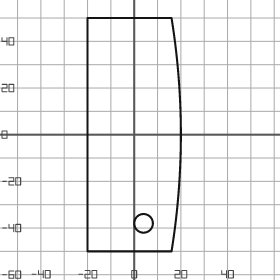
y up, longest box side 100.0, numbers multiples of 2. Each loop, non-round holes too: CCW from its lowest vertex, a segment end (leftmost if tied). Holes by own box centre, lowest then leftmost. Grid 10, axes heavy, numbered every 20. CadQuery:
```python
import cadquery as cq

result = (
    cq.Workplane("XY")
    .moveTo(-20.0, -50.0)
    .lineTo(16.0, -50.0)
    .threePointArc((20.0, 0.0), (16.0, 50.0))
    .lineTo(-20.0, 50.0)
    .close()
    .moveTo(4.0, -38.0)
    .circle(4.0)
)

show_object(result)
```